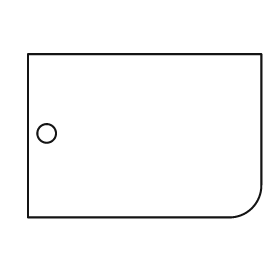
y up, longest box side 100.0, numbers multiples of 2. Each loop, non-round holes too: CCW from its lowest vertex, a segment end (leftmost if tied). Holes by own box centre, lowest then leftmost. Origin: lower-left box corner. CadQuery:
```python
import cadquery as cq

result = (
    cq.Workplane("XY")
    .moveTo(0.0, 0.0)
    .lineTo(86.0, 0.0)
    .threePointArc((96.0, 4.0), (100.0, 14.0))
    .lineTo(100.0, 70.0)
    .lineTo(0.0, 70.0)
    .close()
    .moveTo(8.0, 36.0)
    .circle(4.0)
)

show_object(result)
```